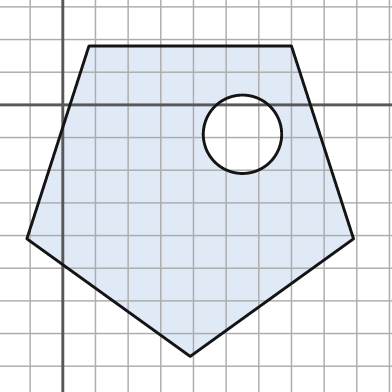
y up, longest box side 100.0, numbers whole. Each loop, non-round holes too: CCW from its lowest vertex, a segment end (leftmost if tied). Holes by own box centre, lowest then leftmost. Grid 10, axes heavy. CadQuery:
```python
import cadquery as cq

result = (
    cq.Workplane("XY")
    .moveTo(39.0, -77.0)
    .lineTo(89.0, -41.0)
    .lineTo(70.0, 18.0)
    .lineTo(8.0, 18.0)
    .lineTo(-11.0, -41.0)
    .close()
    .moveTo(55.0, -9.0)
    .circle(12.0)
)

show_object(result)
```